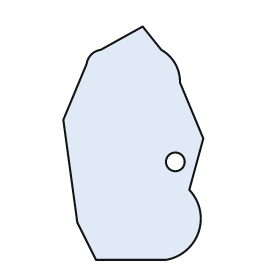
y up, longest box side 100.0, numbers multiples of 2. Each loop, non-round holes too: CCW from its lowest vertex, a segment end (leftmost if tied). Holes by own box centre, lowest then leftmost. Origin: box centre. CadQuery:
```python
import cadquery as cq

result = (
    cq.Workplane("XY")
    .moveTo(-16.0, -50.0)
    .lineTo(14.0, -50.0)
    .threePointArc((28.0, -38.0), (24.0, -20.0))
    .lineTo(30.0, 2.0)
    .lineTo(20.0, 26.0)
    .threePointArc((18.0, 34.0), (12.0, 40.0))
    .lineTo(4.0, 50.0)
    .lineTo(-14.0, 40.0)
    .threePointArc((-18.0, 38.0), (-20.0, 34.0))
    .lineTo(-30.0, 10.0)
    .lineTo(-24.0, -34.0)
    .close()
    .moveTo(18.0, -8.0)
    .circle(4.0)
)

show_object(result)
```